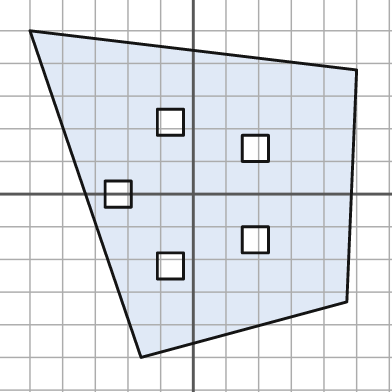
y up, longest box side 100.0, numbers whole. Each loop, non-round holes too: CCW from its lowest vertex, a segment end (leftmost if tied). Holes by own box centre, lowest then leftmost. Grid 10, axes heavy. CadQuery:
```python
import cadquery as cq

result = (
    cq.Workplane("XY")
    .moveTo(-16.0, -50.0)
    .lineTo(47.0, -33.0)
    .lineTo(50.0, 38.0)
    .lineTo(-50.0, 50.0)
    .close()
    .moveTo(-11.0, -26.0)
    .lineTo(-3.0, -26.0)
    .lineTo(-3.0, -18.0)
    .lineTo(-11.0, -18.0)
    .close()
    .moveTo(15.0, -18.0)
    .lineTo(23.0, -18.0)
    .lineTo(23.0, -10.0)
    .lineTo(15.0, -10.0)
    .close()
    .moveTo(-27.0, -4.0)
    .lineTo(-19.0, -4.0)
    .lineTo(-19.0, 4.0)
    .lineTo(-27.0, 4.0)
    .close()
    .moveTo(15.0, 10.0)
    .lineTo(23.0, 10.0)
    .lineTo(23.0, 18.0)
    .lineTo(15.0, 18.0)
    .close()
    .moveTo(-11.0, 18.0)
    .lineTo(-3.0, 18.0)
    .lineTo(-3.0, 26.0)
    .lineTo(-11.0, 26.0)
    .close()
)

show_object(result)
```